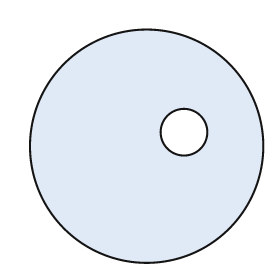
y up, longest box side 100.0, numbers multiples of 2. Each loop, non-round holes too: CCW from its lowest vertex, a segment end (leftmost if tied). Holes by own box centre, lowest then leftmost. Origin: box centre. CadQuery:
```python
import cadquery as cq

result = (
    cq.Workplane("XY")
    .moveTo(0.0, 0.0)
    .circle(50.0)
    .moveTo(16.0, 6.0)
    .circle(10.0)
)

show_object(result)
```